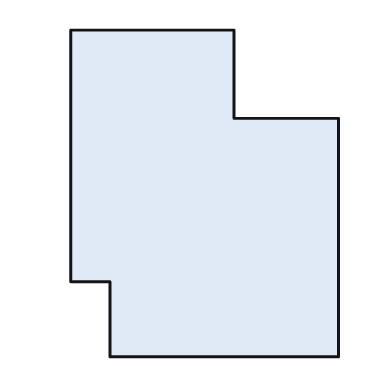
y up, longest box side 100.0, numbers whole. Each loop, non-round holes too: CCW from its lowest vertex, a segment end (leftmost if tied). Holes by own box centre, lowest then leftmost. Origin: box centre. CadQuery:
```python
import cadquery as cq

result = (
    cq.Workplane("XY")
    .moveTo(-29.0, -50.0)
    .lineTo(41.0, -50.0)
    .lineTo(41.0, 23.0)
    .lineTo(9.0, 23.0)
    .lineTo(9.0, 50.0)
    .lineTo(-41.0, 50.0)
    .lineTo(-41.0, -27.0)
    .lineTo(-29.0, -27.0)
    .close()
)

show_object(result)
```